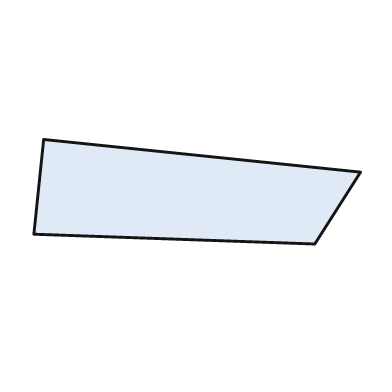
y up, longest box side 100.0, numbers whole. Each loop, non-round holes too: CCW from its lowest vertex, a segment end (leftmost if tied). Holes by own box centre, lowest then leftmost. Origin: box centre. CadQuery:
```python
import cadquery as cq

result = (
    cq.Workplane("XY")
    .moveTo(36.0, -16.0)
    .lineTo(50.0, 6.0)
    .lineTo(-47.0, 16.0)
    .lineTo(-50.0, -13.0)
    .close()
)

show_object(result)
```